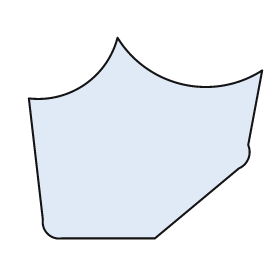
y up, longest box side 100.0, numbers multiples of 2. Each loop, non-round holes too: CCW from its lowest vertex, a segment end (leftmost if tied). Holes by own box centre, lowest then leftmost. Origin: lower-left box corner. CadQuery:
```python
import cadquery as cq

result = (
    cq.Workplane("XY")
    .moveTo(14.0, 0.0)
    .lineTo(54.0, 0.0)
    .lineTo(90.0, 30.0)
    .threePointArc((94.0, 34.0), (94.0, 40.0))
    .lineTo(100.0, 72.0)
    .threePointArc((66.0, 66.0), (38.0, 86.0))
    .threePointArc((24.0, 66.0), (0.0, 60.0))
    .lineTo(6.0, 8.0)
    .threePointArc((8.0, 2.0), (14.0, 0.0))
    .close()
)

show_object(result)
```